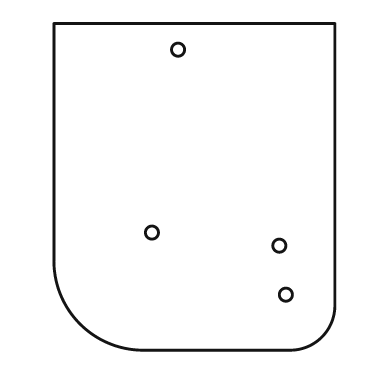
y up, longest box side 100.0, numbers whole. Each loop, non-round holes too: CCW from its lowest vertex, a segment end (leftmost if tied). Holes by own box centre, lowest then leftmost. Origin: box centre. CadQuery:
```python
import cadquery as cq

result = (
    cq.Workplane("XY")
    .moveTo(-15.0, -50.0)
    .lineTo(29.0, -50.0)
    .threePointArc((39.0, -46.0), (43.0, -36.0))
    .lineTo(43.0, 50.0)
    .lineTo(-43.0, 50.0)
    .lineTo(-43.0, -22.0)
    .threePointArc((-35.0, -42.0), (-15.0, -50.0))
    .close()
    .moveTo(28.0, -33.0)
    .circle(2.0)
    .moveTo(26.0, -18.0)
    .circle(2.0)
    .moveTo(-13.0, -14.0)
    .circle(2.0)
    .moveTo(-5.0, 42.0)
    .circle(2.0)
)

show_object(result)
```